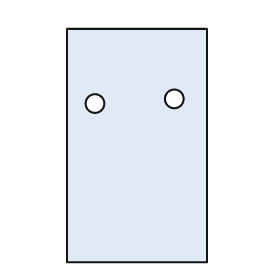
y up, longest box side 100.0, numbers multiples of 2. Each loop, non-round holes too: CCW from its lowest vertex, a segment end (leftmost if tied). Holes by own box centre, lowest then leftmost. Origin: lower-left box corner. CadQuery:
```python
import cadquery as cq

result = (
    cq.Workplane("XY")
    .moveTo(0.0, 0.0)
    .lineTo(60.0, 0.0)
    .lineTo(60.0, 100.0)
    .lineTo(0.0, 100.0)
    .close()
    .moveTo(12.0, 68.0)
    .circle(4.0)
    .moveTo(46.0, 70.0)
    .circle(4.0)
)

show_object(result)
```